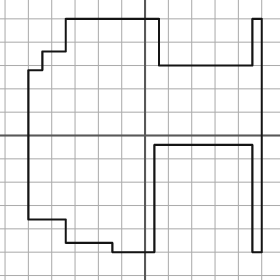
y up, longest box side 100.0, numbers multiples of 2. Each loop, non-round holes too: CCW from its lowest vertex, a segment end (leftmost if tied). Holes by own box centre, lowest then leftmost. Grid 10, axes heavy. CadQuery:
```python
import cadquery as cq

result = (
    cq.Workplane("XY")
    .moveTo(-14.0, -50.0)
    .lineTo(4.0, -50.0)
    .lineTo(4.0, -4.0)
    .lineTo(46.0, -4.0)
    .lineTo(46.0, -50.0)
    .lineTo(50.0, -50.0)
    .lineTo(50.0, 50.0)
    .lineTo(46.0, 50.0)
    .lineTo(46.0, 30.0)
    .lineTo(6.0, 30.0)
    .lineTo(6.0, 50.0)
    .lineTo(-34.0, 50.0)
    .lineTo(-34.0, 36.0)
    .lineTo(-44.0, 36.0)
    .lineTo(-44.0, 28.0)
    .lineTo(-50.0, 28.0)
    .lineTo(-50.0, -36.0)
    .lineTo(-34.0, -36.0)
    .lineTo(-34.0, -46.0)
    .lineTo(-14.0, -46.0)
    .close()
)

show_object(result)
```